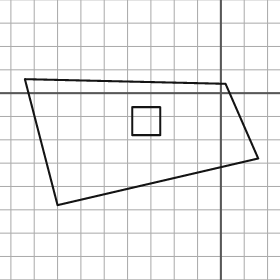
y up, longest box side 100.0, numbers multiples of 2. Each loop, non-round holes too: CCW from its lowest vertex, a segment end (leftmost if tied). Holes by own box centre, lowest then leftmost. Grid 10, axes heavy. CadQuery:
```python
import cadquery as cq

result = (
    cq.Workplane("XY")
    .moveTo(-70.0, -48.0)
    .lineTo(16.0, -28.0)
    .lineTo(2.0, 4.0)
    .lineTo(-84.0, 6.0)
    .close()
    .moveTo(-38.0, -18.0)
    .lineTo(-26.0, -18.0)
    .lineTo(-26.0, -6.0)
    .lineTo(-38.0, -6.0)
    .close()
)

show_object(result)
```